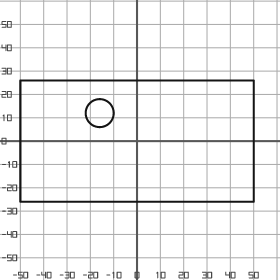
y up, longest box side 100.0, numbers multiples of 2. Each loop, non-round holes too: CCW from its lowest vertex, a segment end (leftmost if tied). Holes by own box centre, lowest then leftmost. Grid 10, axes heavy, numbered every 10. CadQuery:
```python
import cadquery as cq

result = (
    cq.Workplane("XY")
    .moveTo(-50.0, -26.0)
    .lineTo(50.0, -26.0)
    .lineTo(50.0, 26.0)
    .lineTo(-50.0, 26.0)
    .close()
    .moveTo(-16.0, 12.0)
    .circle(6.0)
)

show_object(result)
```